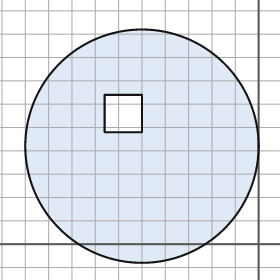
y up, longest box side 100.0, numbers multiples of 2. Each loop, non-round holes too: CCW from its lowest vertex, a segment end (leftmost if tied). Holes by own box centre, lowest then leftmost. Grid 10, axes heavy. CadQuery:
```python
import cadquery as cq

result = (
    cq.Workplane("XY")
    .moveTo(-50.0, 42.0)
    .circle(50.0)
    .moveTo(-66.0, 48.0)
    .lineTo(-50.0, 48.0)
    .lineTo(-50.0, 64.0)
    .lineTo(-66.0, 64.0)
    .close()
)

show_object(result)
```